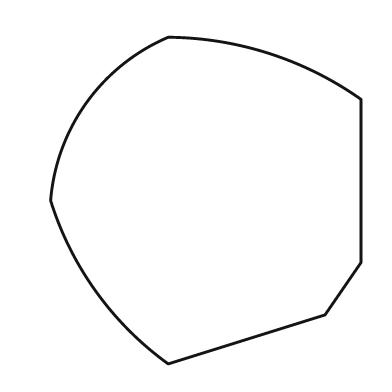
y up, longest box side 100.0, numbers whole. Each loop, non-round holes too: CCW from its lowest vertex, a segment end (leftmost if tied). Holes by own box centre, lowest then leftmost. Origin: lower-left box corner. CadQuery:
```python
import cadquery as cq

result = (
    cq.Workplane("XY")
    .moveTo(36.0, 0.0)
    .lineTo(84.0, 15.0)
    .lineTo(95.0, 31.0)
    .lineTo(95.0, 81.0)
    .threePointArc((67.0, 95.0), (36.0, 100.0))
    .threePointArc((11.0, 80.0), (0.0, 50.0))
    .threePointArc((14.0, 22.0), (36.0, 0.0))
    .close()
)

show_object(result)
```